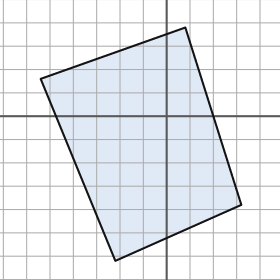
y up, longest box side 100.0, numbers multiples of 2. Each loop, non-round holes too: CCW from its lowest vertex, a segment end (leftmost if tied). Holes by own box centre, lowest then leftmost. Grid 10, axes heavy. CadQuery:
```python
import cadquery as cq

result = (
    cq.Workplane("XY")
    .moveTo(-22.0, -62.0)
    .lineTo(32.0, -38.0)
    .lineTo(8.0, 38.0)
    .lineTo(-54.0, 16.0)
    .close()
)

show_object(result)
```